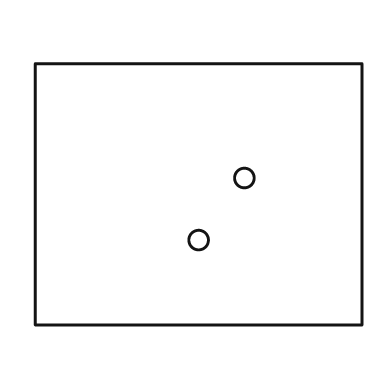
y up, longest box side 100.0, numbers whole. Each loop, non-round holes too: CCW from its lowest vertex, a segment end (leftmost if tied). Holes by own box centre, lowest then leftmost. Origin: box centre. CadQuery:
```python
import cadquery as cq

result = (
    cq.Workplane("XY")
    .moveTo(-50.0, -40.0)
    .lineTo(50.0, -40.0)
    .lineTo(50.0, 40.0)
    .lineTo(-50.0, 40.0)
    .close()
    .moveTo(0.0, -14.0)
    .circle(3.0)
    .moveTo(14.0, 5.0)
    .circle(3.0)
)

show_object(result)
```